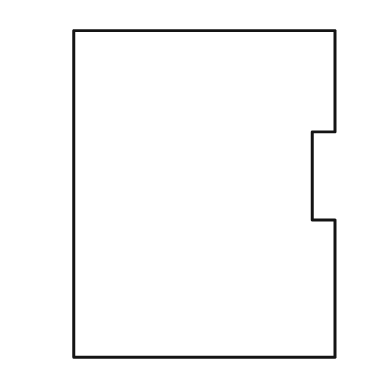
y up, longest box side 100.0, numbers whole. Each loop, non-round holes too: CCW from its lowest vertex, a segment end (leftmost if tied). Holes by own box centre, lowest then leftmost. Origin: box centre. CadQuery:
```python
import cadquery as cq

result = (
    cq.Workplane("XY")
    .moveTo(-40.0, -50.0)
    .lineTo(40.0, -50.0)
    .lineTo(40.0, -8.0)
    .lineTo(33.0, -8.0)
    .lineTo(33.0, 19.0)
    .lineTo(40.0, 19.0)
    .lineTo(40.0, 50.0)
    .lineTo(-40.0, 50.0)
    .close()
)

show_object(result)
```